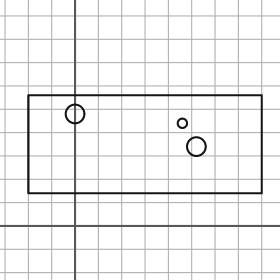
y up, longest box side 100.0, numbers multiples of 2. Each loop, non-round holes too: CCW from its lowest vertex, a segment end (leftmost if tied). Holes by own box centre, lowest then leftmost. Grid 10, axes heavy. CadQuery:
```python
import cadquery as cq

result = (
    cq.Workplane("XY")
    .moveTo(-20.0, 14.0)
    .lineTo(80.0, 14.0)
    .lineTo(80.0, 56.0)
    .lineTo(-20.0, 56.0)
    .close()
    .moveTo(52.0, 34.0)
    .circle(4.0)
    .moveTo(46.0, 44.0)
    .circle(2.0)
    .moveTo(0.0, 48.0)
    .circle(4.0)
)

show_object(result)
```